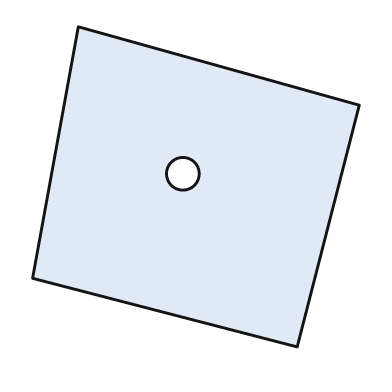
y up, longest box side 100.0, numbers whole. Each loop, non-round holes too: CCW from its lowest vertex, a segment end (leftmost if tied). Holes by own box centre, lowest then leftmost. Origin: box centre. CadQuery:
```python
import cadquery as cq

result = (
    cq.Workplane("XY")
    .moveTo(31.0, -49.0)
    .lineTo(50.0, 25.0)
    .lineTo(-36.0, 49.0)
    .lineTo(-50.0, -28.0)
    .close()
    .moveTo(-4.0, 4.0)
    .circle(5.0)
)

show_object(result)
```